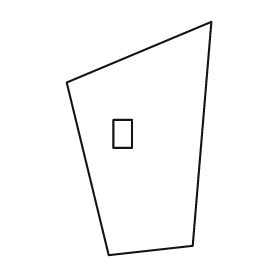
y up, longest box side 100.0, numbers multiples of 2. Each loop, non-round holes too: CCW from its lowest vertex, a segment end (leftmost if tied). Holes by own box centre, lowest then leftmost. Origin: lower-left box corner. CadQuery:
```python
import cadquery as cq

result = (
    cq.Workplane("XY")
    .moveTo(18.0, 0.0)
    .lineTo(54.0, 4.0)
    .lineTo(62.0, 100.0)
    .lineTo(0.0, 74.0)
    .close()
    .moveTo(20.0, 46.0)
    .lineTo(28.0, 46.0)
    .lineTo(28.0, 58.0)
    .lineTo(20.0, 58.0)
    .close()
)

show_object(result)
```